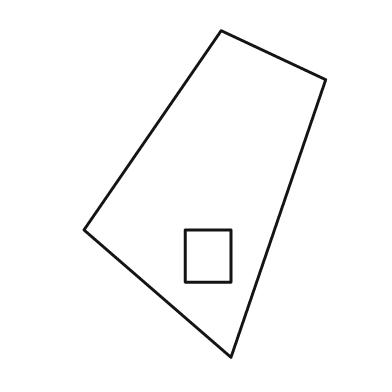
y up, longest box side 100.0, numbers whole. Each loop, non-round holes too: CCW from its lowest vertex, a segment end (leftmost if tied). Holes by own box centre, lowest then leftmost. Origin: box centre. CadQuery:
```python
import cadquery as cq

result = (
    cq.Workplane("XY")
    .moveTo(8.0, -50.0)
    .lineTo(37.0, 35.0)
    .lineTo(5.0, 50.0)
    .lineTo(-37.0, -11.0)
    .close()
    .moveTo(-6.0, -27.0)
    .lineTo(8.0, -27.0)
    .lineTo(8.0, -11.0)
    .lineTo(-6.0, -11.0)
    .close()
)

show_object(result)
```